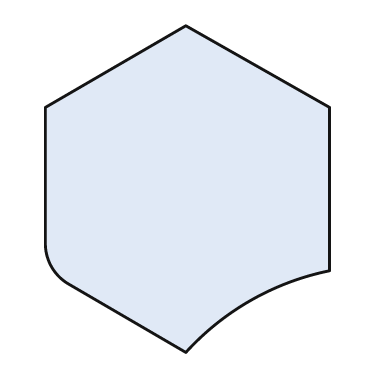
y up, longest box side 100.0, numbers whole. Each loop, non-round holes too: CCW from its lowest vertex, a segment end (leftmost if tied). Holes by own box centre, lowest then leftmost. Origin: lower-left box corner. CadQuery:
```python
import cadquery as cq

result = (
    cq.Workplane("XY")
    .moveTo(43.0, 0.0)
    .threePointArc((63.0, 16.0), (87.0, 25.0))
    .lineTo(87.0, 75.0)
    .lineTo(43.0, 100.0)
    .lineTo(0.0, 75.0)
    .lineTo(0.0, 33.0)
    .threePointArc((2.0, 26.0), (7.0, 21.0))
    .close()
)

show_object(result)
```